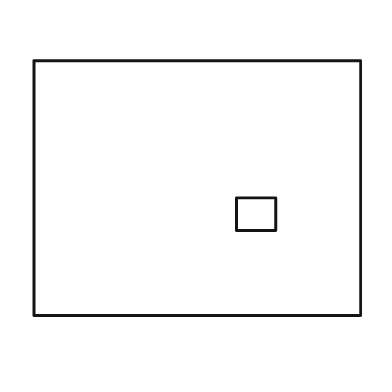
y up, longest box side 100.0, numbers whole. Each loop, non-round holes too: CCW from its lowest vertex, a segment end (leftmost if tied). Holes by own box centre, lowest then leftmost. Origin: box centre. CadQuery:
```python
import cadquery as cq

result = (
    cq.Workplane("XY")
    .moveTo(-50.0, -39.0)
    .lineTo(50.0, -39.0)
    .lineTo(50.0, 39.0)
    .lineTo(-50.0, 39.0)
    .close()
    .moveTo(12.0, -13.0)
    .lineTo(24.0, -13.0)
    .lineTo(24.0, -3.0)
    .lineTo(12.0, -3.0)
    .close()
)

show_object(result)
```